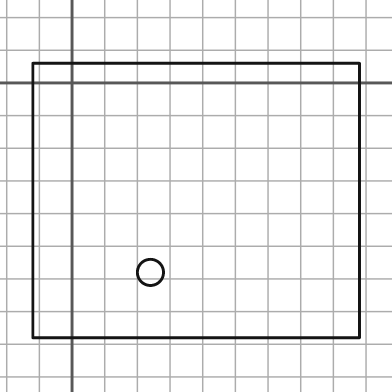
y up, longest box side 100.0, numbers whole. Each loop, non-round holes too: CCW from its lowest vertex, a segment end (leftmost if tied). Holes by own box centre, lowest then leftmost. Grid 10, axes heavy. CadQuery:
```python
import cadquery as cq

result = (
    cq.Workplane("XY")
    .moveTo(-12.0, -78.0)
    .lineTo(88.0, -78.0)
    .lineTo(88.0, 6.0)
    .lineTo(-12.0, 6.0)
    .close()
    .moveTo(24.0, -58.0)
    .circle(4.0)
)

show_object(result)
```